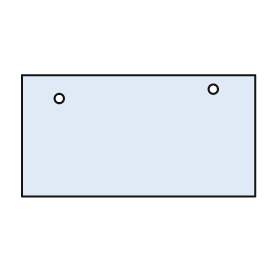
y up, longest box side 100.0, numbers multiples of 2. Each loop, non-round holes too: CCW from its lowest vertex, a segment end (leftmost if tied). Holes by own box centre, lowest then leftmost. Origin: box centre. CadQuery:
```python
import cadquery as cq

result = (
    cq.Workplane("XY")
    .moveTo(-50.0, -26.0)
    .lineTo(50.0, -26.0)
    .lineTo(50.0, 26.0)
    .lineTo(-50.0, 26.0)
    .close()
    .moveTo(-34.0, 16.0)
    .circle(2.0)
    .moveTo(32.0, 20.0)
    .circle(2.0)
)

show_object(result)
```